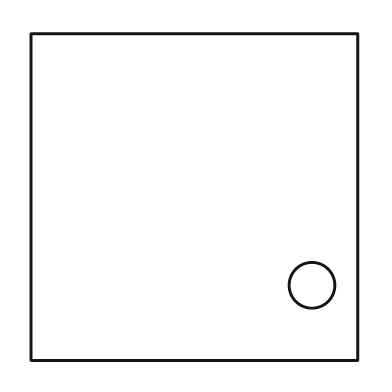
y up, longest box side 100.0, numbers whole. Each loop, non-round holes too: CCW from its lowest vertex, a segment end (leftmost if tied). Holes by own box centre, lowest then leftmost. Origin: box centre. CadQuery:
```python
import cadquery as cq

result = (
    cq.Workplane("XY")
    .moveTo(-50.0, -50.0)
    .lineTo(50.0, -50.0)
    .lineTo(50.0, 50.0)
    .lineTo(-50.0, 50.0)
    .close()
    .moveTo(36.0, -27.0)
    .circle(7.0)
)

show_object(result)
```